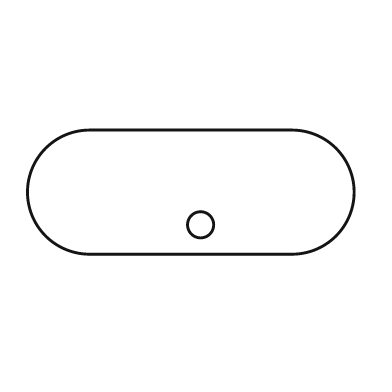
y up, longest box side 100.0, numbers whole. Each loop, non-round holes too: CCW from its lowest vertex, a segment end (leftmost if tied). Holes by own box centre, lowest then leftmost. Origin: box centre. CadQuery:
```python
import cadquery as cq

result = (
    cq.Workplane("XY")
    .moveTo(-31.0, -19.0)
    .lineTo(31.0, -19.0)
    .threePointArc((50.0, 0.0), (31.0, 19.0))
    .lineTo(-31.0, 19.0)
    .threePointArc((-50.0, 0.0), (-31.0, -19.0))
    .close()
    .moveTo(3.0, -10.0)
    .circle(4.0)
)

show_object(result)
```